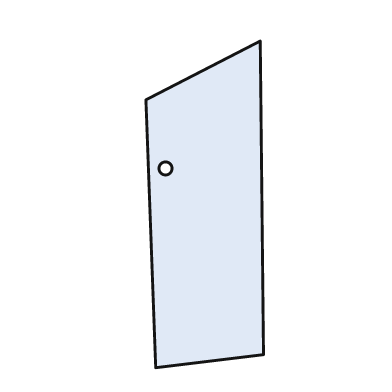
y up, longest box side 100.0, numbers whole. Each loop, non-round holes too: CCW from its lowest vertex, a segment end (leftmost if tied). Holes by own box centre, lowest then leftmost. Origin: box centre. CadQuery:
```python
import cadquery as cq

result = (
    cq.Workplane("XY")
    .moveTo(-15.0, -50.0)
    .lineTo(18.0, -46.0)
    .lineTo(17.0, 50.0)
    .lineTo(-18.0, 32.0)
    .close()
    .moveTo(-12.0, 11.0)
    .circle(2.0)
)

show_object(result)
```